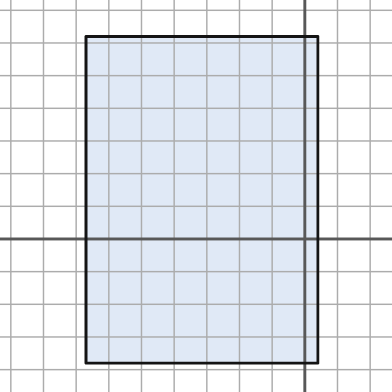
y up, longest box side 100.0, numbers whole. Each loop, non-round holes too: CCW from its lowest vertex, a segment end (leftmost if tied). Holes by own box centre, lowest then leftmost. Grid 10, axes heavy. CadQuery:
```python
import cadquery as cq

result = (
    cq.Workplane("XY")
    .moveTo(-67.0, -38.0)
    .lineTo(4.0, -38.0)
    .lineTo(4.0, 62.0)
    .lineTo(-67.0, 62.0)
    .close()
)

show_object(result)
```